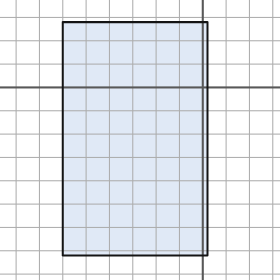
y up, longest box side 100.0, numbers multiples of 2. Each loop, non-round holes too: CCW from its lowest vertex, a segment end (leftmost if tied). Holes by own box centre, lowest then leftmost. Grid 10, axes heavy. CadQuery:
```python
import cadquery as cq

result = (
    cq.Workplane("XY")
    .moveTo(-60.0, -72.0)
    .lineTo(2.0, -72.0)
    .lineTo(2.0, 28.0)
    .lineTo(-60.0, 28.0)
    .close()
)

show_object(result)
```